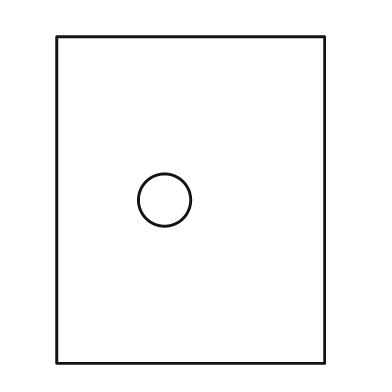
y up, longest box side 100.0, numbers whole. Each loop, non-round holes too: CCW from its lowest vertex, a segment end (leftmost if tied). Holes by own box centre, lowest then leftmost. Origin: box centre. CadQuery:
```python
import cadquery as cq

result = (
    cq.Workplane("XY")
    .moveTo(-41.0, -50.0)
    .lineTo(41.0, -50.0)
    .lineTo(41.0, 50.0)
    .lineTo(-41.0, 50.0)
    .close()
    .moveTo(-8.0, 0.0)
    .circle(8.0)
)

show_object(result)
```